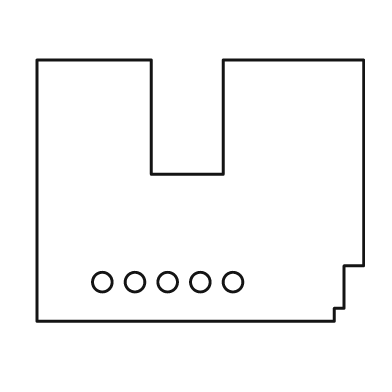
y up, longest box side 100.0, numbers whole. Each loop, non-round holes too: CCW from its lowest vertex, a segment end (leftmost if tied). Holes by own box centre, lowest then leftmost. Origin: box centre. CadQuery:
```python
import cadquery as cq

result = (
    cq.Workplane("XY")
    .moveTo(-50.0, -40.0)
    .lineTo(41.0, -40.0)
    .lineTo(41.0, -36.0)
    .lineTo(44.0, -36.0)
    .lineTo(44.0, -23.0)
    .lineTo(50.0, -23.0)
    .lineTo(50.0, 40.0)
    .lineTo(7.0, 40.0)
    .lineTo(7.0, 5.0)
    .lineTo(-15.0, 5.0)
    .lineTo(-15.0, 40.0)
    .lineTo(-50.0, 40.0)
    .close()
    .moveTo(-30.0, -28.0)
    .circle(3.0)
    .moveTo(-20.0, -28.0)
    .circle(3.0)
    .moveTo(-10.0, -28.0)
    .circle(3.0)
    .moveTo(0.0, -28.0)
    .circle(3.0)
    .moveTo(10.0, -28.0)
    .circle(3.0)
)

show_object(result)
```